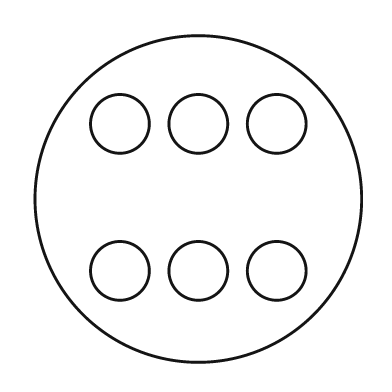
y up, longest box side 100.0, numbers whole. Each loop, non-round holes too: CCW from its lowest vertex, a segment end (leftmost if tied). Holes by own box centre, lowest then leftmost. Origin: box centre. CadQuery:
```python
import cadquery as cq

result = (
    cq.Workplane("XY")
    .moveTo(0.0, 0.0)
    .circle(50.0)
    .moveTo(-24.0, -22.0)
    .circle(9.0)
    .moveTo(0.0, -22.0)
    .circle(9.0)
    .moveTo(24.0, -22.0)
    .circle(9.0)
    .moveTo(-24.0, 23.0)
    .circle(9.0)
    .moveTo(0.0, 23.0)
    .circle(9.0)
    .moveTo(24.0, 23.0)
    .circle(9.0)
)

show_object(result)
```